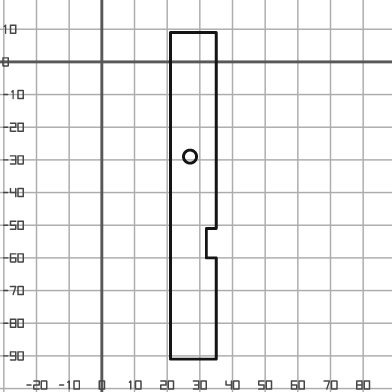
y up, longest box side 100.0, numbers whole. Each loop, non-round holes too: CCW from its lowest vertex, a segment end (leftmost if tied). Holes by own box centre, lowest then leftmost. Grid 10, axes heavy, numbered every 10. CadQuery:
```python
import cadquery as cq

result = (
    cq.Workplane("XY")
    .moveTo(21.0, -91.0)
    .lineTo(35.0, -91.0)
    .lineTo(35.0, -60.0)
    .lineTo(32.0, -60.0)
    .lineTo(32.0, -51.0)
    .lineTo(35.0, -51.0)
    .lineTo(35.0, 9.0)
    .lineTo(21.0, 9.0)
    .close()
    .moveTo(27.0, -29.0)
    .circle(2.0)
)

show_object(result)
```